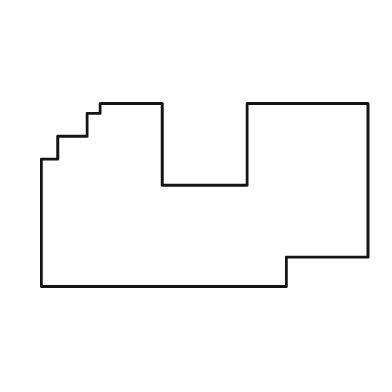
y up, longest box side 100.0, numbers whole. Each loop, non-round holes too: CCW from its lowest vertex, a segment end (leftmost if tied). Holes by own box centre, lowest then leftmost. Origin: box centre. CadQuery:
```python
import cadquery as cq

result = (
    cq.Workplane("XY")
    .moveTo(-50.0, -28.0)
    .lineTo(25.0, -28.0)
    .lineTo(25.0, -19.0)
    .lineTo(50.0, -19.0)
    .lineTo(50.0, 28.0)
    .lineTo(13.0, 28.0)
    .lineTo(13.0, 3.0)
    .lineTo(-13.0, 3.0)
    .lineTo(-13.0, 28.0)
    .lineTo(-32.0, 28.0)
    .lineTo(-32.0, 25.0)
    .lineTo(-36.0, 25.0)
    .lineTo(-36.0, 18.0)
    .lineTo(-45.0, 18.0)
    .lineTo(-45.0, 11.0)
    .lineTo(-50.0, 11.0)
    .close()
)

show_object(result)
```